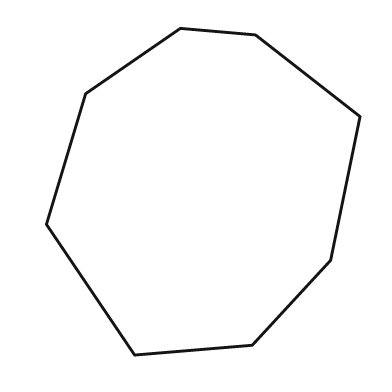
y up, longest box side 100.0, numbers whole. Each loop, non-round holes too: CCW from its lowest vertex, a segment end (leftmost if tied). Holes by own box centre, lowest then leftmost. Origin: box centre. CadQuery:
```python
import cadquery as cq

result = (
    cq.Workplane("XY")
    .moveTo(-21.0, -50.0)
    .lineTo(15.0, -47.0)
    .lineTo(39.0, -21.0)
    .lineTo(48.0, 23.0)
    .lineTo(16.0, 48.0)
    .lineTo(-7.0, 50.0)
    .lineTo(-36.0, 30.0)
    .lineTo(-48.0, -10.0)
    .close()
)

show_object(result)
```